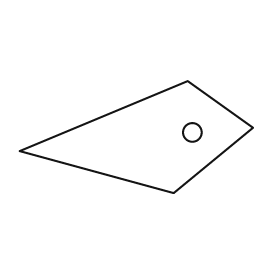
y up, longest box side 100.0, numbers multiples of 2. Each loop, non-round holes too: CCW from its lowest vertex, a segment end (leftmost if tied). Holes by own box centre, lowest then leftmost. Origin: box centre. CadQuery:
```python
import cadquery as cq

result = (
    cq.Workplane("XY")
    .moveTo(16.0, -24.0)
    .lineTo(50.0, 4.0)
    .lineTo(22.0, 24.0)
    .lineTo(-50.0, -6.0)
    .close()
    .moveTo(24.0, 2.0)
    .circle(4.0)
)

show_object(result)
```